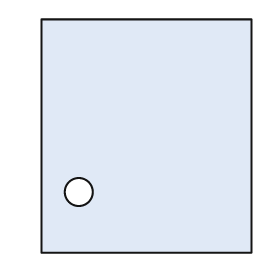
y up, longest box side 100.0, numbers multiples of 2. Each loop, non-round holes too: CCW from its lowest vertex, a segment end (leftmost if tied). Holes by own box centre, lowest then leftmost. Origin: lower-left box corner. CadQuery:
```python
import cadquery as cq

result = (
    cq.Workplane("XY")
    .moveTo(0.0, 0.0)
    .lineTo(90.0, 0.0)
    .lineTo(90.0, 100.0)
    .lineTo(0.0, 100.0)
    .close()
    .moveTo(16.0, 26.0)
    .circle(6.0)
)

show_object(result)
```